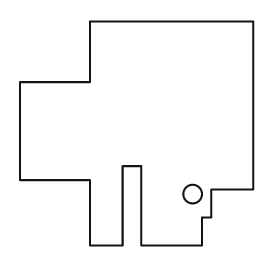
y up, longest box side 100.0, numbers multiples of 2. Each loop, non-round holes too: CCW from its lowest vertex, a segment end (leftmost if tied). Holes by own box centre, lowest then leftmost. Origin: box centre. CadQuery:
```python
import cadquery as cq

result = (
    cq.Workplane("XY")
    .moveTo(-20.0, -48.0)
    .lineTo(-6.0, -48.0)
    .lineTo(-6.0, -14.0)
    .lineTo(2.0, -14.0)
    .lineTo(2.0, -48.0)
    .lineTo(28.0, -48.0)
    .lineTo(28.0, -36.0)
    .lineTo(32.0, -36.0)
    .lineTo(32.0, -24.0)
    .lineTo(50.0, -24.0)
    .lineTo(50.0, 48.0)
    .lineTo(-20.0, 48.0)
    .lineTo(-20.0, 22.0)
    .lineTo(-50.0, 22.0)
    .lineTo(-50.0, -20.0)
    .lineTo(-20.0, -20.0)
    .close()
    .moveTo(24.0, -26.0)
    .circle(4.0)
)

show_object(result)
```